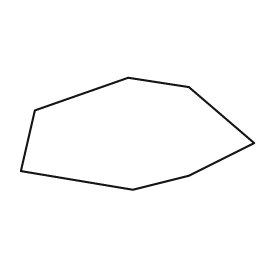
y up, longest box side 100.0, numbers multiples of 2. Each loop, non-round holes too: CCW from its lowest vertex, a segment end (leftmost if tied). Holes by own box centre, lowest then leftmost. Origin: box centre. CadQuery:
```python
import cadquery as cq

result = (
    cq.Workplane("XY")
    .moveTo(-2.0, -24.0)
    .lineTo(22.0, -18.0)
    .lineTo(50.0, -4.0)
    .lineTo(22.0, 20.0)
    .lineTo(-4.0, 24.0)
    .lineTo(-44.0, 10.0)
    .lineTo(-50.0, -16.0)
    .close()
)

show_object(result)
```